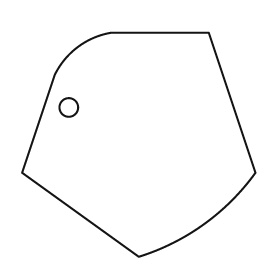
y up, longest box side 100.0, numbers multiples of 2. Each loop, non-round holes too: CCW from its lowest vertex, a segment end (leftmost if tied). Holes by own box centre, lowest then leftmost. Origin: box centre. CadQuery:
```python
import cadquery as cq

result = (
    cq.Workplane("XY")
    .moveTo(0.0, -48.0)
    .threePointArc((28.0, -34.0), (50.0, -12.0))
    .lineTo(30.0, 48.0)
    .lineTo(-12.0, 48.0)
    .threePointArc((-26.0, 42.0), (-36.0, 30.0))
    .lineTo(-50.0, -12.0)
    .close()
    .moveTo(-30.0, 16.0)
    .circle(4.0)
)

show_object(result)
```